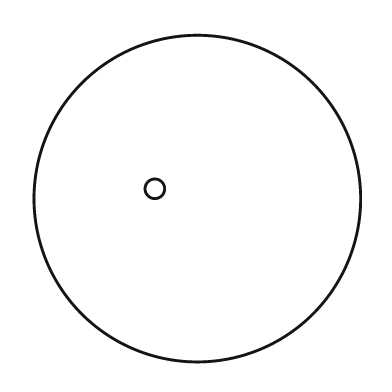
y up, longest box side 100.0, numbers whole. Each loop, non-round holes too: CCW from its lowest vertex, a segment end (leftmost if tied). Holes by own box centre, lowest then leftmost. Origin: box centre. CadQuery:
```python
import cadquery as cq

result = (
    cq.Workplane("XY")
    .moveTo(0.0, 0.0)
    .circle(50.0)
    .moveTo(-13.0, 3.0)
    .circle(3.0)
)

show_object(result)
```